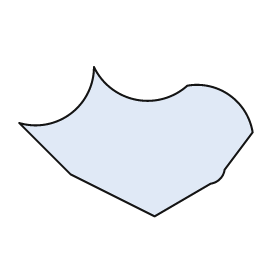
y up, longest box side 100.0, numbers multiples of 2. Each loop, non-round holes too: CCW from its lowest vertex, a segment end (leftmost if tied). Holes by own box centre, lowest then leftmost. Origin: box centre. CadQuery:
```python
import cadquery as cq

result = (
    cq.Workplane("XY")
    .moveTo(8.0, -32.0)
    .lineTo(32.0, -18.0)
    .threePointArc((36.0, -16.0), (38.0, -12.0))
    .lineTo(50.0, 4.0)
    .threePointArc((40.0, 20.0), (22.0, 24.0))
    .threePointArc((0.0, 18.0), (-18.0, 32.0))
    .threePointArc((-28.0, 12.0), (-50.0, 8.0))
    .lineTo(-28.0, -14.0)
    .close()
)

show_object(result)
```